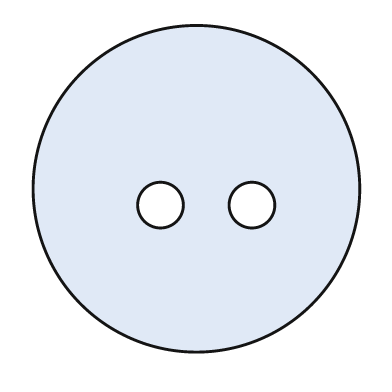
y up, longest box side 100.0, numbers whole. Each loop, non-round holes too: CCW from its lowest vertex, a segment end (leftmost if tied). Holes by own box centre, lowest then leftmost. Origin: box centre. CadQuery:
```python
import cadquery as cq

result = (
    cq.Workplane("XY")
    .moveTo(0.0, 0.0)
    .circle(50.0)
    .moveTo(-11.0, -5.0)
    .circle(7.0)
    .moveTo(17.0, -5.0)
    .circle(7.0)
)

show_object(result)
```